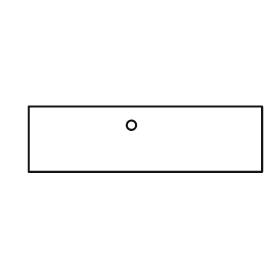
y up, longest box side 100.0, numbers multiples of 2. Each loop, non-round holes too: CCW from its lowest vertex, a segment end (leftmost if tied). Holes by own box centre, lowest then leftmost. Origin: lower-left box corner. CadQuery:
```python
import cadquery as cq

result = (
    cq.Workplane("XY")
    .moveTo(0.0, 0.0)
    .lineTo(100.0, 0.0)
    .lineTo(100.0, 28.0)
    .lineTo(0.0, 28.0)
    .close()
    .moveTo(44.0, 20.0)
    .circle(2.0)
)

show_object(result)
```